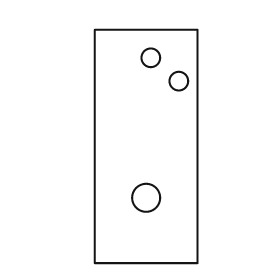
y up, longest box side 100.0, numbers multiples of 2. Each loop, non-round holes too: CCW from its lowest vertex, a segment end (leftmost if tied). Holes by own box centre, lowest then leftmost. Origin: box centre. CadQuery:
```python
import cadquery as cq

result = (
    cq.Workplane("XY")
    .moveTo(-22.0, -50.0)
    .lineTo(22.0, -50.0)
    .lineTo(22.0, 50.0)
    .lineTo(-22.0, 50.0)
    .close()
    .moveTo(0.0, -22.0)
    .circle(6.0)
    .moveTo(14.0, 28.0)
    .circle(4.0)
    .moveTo(2.0, 38.0)
    .circle(4.0)
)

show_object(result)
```